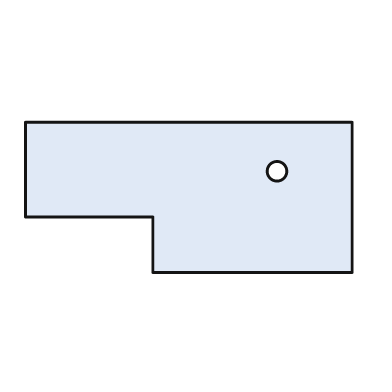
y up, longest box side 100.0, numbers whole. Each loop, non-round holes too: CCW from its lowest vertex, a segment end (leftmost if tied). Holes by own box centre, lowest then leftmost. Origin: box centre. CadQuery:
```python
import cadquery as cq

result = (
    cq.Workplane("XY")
    .moveTo(-11.0, -23.0)
    .lineTo(50.0, -23.0)
    .lineTo(50.0, 23.0)
    .lineTo(-50.0, 23.0)
    .lineTo(-50.0, -6.0)
    .lineTo(-11.0, -6.0)
    .close()
    .moveTo(27.0, 8.0)
    .circle(3.0)
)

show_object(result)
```